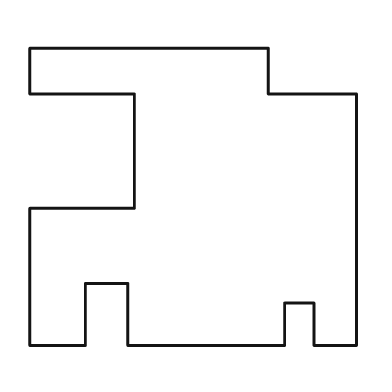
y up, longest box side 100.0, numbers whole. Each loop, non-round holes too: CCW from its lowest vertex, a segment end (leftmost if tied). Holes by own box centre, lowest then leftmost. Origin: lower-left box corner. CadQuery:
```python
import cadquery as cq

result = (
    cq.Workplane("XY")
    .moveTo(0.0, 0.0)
    .lineTo(17.0, 0.0)
    .lineTo(17.0, 19.0)
    .lineTo(30.0, 19.0)
    .lineTo(30.0, 0.0)
    .lineTo(78.0, 0.0)
    .lineTo(78.0, 13.0)
    .lineTo(87.0, 13.0)
    .lineTo(87.0, 0.0)
    .lineTo(100.0, 0.0)
    .lineTo(100.0, 77.0)
    .lineTo(73.0, 77.0)
    .lineTo(73.0, 91.0)
    .lineTo(0.0, 91.0)
    .lineTo(0.0, 77.0)
    .lineTo(32.0, 77.0)
    .lineTo(32.0, 42.0)
    .lineTo(0.0, 42.0)
    .close()
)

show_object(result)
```